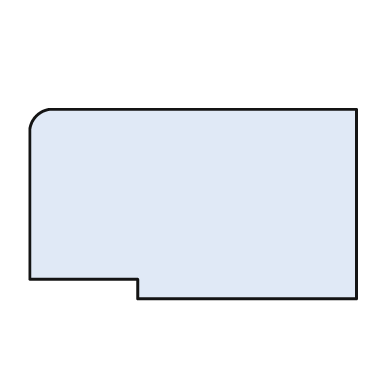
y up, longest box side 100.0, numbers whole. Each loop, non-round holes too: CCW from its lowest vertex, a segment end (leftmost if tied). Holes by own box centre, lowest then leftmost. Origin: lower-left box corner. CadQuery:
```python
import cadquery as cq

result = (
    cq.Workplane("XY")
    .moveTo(33.0, 0.0)
    .lineTo(100.0, 0.0)
    .lineTo(100.0, 58.0)
    .lineTo(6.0, 58.0)
    .threePointArc((2.0, 56.0), (0.0, 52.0))
    .lineTo(0.0, 6.0)
    .lineTo(33.0, 6.0)
    .close()
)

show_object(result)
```